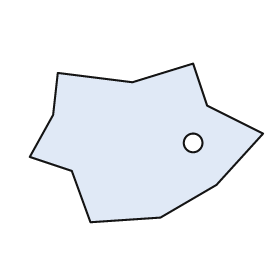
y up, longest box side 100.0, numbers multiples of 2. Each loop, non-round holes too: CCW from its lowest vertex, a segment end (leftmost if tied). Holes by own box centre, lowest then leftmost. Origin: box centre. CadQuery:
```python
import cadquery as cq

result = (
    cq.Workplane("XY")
    .moveTo(-24.0, -34.0)
    .lineTo(6.0, -32.0)
    .lineTo(30.0, -18.0)
    .lineTo(50.0, 4.0)
    .lineTo(26.0, 16.0)
    .lineTo(20.0, 34.0)
    .lineTo(-6.0, 26.0)
    .lineTo(-38.0, 30.0)
    .lineTo(-40.0, 12.0)
    .lineTo(-50.0, -6.0)
    .lineTo(-32.0, -12.0)
    .close()
    .moveTo(20.0, 0.0)
    .circle(4.0)
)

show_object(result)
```